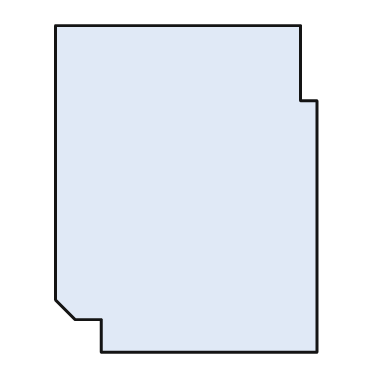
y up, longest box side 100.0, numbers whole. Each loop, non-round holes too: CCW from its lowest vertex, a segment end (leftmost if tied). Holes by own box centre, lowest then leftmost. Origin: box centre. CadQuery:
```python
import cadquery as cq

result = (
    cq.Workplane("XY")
    .moveTo(-26.0, -50.0)
    .lineTo(40.0, -50.0)
    .lineTo(40.0, 27.0)
    .lineTo(35.0, 27.0)
    .lineTo(35.0, 50.0)
    .lineTo(-40.0, 50.0)
    .lineTo(-40.0, -34.0)
    .lineTo(-34.0, -40.0)
    .lineTo(-26.0, -40.0)
    .close()
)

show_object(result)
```